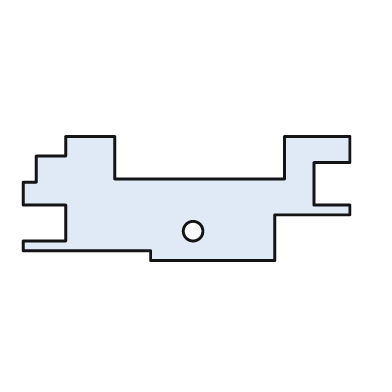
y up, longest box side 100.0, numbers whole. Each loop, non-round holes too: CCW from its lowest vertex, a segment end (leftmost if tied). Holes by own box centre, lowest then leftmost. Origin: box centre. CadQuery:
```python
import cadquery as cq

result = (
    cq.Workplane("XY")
    .moveTo(-11.0, -19.0)
    .lineTo(27.0, -19.0)
    .lineTo(27.0, -5.0)
    .lineTo(50.0, -5.0)
    .lineTo(50.0, -2.0)
    .lineTo(39.0, -2.0)
    .lineTo(39.0, 11.0)
    .lineTo(50.0, 11.0)
    .lineTo(50.0, 19.0)
    .lineTo(30.0, 19.0)
    .lineTo(30.0, 6.0)
    .lineTo(-22.0, 6.0)
    .lineTo(-22.0, 19.0)
    .lineTo(-37.0, 19.0)
    .lineTo(-37.0, 13.0)
    .lineTo(-46.0, 13.0)
    .lineTo(-46.0, 5.0)
    .lineTo(-50.0, 5.0)
    .lineTo(-50.0, -2.0)
    .lineTo(-37.0, -2.0)
    .lineTo(-37.0, -13.0)
    .lineTo(-50.0, -13.0)
    .lineTo(-50.0, -16.0)
    .lineTo(-11.0, -16.0)
    .close()
    .moveTo(2.0, -10.0)
    .circle(3.0)
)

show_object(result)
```